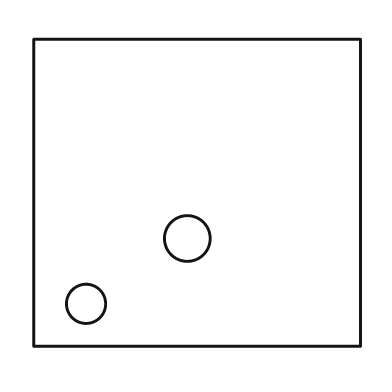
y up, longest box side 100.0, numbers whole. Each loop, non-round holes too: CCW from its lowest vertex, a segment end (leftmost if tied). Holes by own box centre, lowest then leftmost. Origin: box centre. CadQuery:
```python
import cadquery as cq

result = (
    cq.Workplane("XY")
    .moveTo(-50.0, -47.0)
    .lineTo(50.0, -47.0)
    .lineTo(50.0, 47.0)
    .lineTo(-50.0, 47.0)
    .close()
    .moveTo(-34.0, -34.0)
    .circle(6.0)
    .moveTo(-3.0, -14.0)
    .circle(7.0)
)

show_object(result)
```